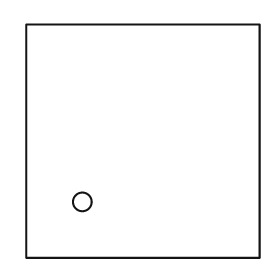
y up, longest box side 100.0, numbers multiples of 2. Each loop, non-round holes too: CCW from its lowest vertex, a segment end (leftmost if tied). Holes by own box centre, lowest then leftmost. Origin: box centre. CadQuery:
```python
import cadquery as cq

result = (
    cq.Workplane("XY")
    .moveTo(-50.0, -50.0)
    .lineTo(50.0, -50.0)
    .lineTo(50.0, 50.0)
    .lineTo(-50.0, 50.0)
    .close()
    .moveTo(-26.0, -26.0)
    .circle(4.0)
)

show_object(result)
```